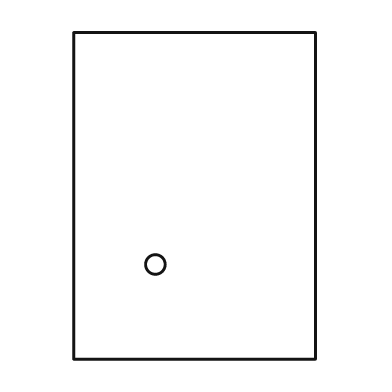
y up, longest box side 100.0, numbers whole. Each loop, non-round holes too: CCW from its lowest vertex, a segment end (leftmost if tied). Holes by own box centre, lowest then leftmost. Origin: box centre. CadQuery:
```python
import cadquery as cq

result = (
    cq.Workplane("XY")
    .moveTo(-37.0, -50.0)
    .lineTo(37.0, -50.0)
    .lineTo(37.0, 50.0)
    .lineTo(-37.0, 50.0)
    .close()
    .moveTo(-12.0, -21.0)
    .circle(3.0)
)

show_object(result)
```